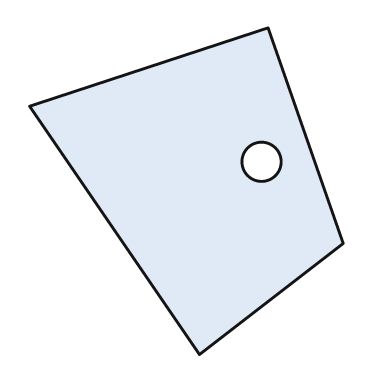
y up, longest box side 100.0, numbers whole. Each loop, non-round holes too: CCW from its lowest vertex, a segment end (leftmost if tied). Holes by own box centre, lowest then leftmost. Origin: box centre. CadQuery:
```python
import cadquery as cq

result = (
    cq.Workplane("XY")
    .moveTo(4.0, -50.0)
    .lineTo(48.0, -16.0)
    .lineTo(25.0, 50.0)
    .lineTo(-48.0, 26.0)
    .close()
    .moveTo(23.0, 9.0)
    .circle(6.0)
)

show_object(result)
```